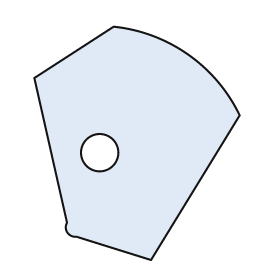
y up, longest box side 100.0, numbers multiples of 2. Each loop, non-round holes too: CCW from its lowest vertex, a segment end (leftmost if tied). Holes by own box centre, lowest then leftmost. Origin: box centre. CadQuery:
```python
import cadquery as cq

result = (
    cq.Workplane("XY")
    .moveTo(6.0, -50.0)
    .lineTo(44.0, 12.0)
    .threePointArc((22.0, 38.0), (-10.0, 50.0))
    .lineTo(-44.0, 28.0)
    .lineTo(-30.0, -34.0)
    .threePointArc((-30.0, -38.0), (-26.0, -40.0))
    .close()
    .moveTo(-16.0, -4.0)
    .circle(8.0)
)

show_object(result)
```